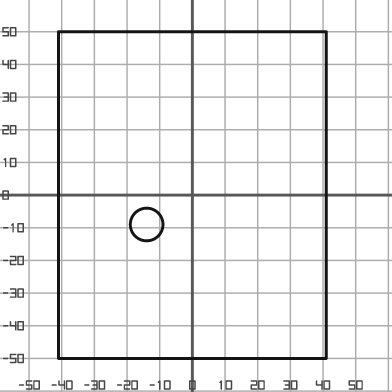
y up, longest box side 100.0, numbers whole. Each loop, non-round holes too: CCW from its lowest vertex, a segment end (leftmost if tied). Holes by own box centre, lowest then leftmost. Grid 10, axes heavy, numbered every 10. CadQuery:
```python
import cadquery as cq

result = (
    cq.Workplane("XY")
    .moveTo(-41.0, -50.0)
    .lineTo(41.0, -50.0)
    .lineTo(41.0, 50.0)
    .lineTo(-41.0, 50.0)
    .close()
    .moveTo(-14.0, -9.0)
    .circle(5.0)
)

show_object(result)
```